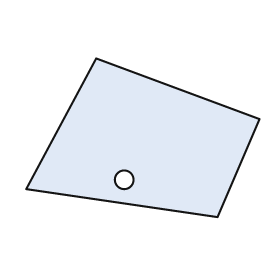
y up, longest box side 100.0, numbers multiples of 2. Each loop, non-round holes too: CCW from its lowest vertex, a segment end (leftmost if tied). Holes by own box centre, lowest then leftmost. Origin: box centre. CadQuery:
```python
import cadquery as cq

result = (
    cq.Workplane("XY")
    .moveTo(32.0, -34.0)
    .lineTo(50.0, 8.0)
    .lineTo(-20.0, 34.0)
    .lineTo(-50.0, -22.0)
    .close()
    .moveTo(-8.0, -18.0)
    .circle(4.0)
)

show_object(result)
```